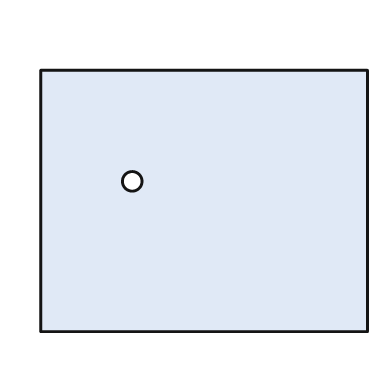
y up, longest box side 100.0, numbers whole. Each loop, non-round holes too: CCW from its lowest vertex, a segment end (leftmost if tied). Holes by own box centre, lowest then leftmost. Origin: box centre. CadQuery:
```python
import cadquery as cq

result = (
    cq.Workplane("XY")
    .moveTo(-50.0, -40.0)
    .lineTo(50.0, -40.0)
    .lineTo(50.0, 40.0)
    .lineTo(-50.0, 40.0)
    .close()
    .moveTo(-22.0, 6.0)
    .circle(3.0)
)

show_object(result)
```